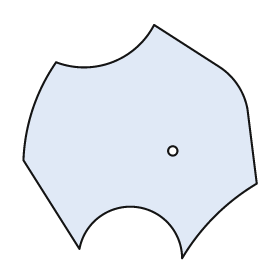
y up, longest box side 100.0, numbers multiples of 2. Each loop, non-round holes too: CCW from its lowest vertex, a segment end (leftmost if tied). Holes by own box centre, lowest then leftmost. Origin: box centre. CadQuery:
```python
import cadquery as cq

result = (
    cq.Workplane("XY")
    .moveTo(18.0, -50.0)
    .threePointArc((32.0, -32.0), (50.0, -18.0))
    .lineTo(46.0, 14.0)
    .threePointArc((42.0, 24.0), (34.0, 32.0))
    .lineTo(6.0, 50.0)
    .threePointArc((-12.0, 34.0), (-36.0, 34.0))
    .threePointArc((-46.0, 14.0), (-50.0, -8.0))
    .lineTo(-26.0, -46.0)
    .threePointArc((-2.0, -28.0), (18.0, -50.0))
    .close()
    .moveTo(14.0, -4.0)
    .circle(2.0)
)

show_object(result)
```